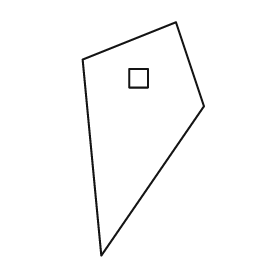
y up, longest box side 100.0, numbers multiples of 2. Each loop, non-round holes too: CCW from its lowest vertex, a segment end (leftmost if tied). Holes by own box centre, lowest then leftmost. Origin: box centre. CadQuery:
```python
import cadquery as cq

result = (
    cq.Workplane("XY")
    .moveTo(-18.0, -50.0)
    .lineTo(26.0, 14.0)
    .lineTo(14.0, 50.0)
    .lineTo(-26.0, 34.0)
    .close()
    .moveTo(-6.0, 22.0)
    .lineTo(2.0, 22.0)
    .lineTo(2.0, 30.0)
    .lineTo(-6.0, 30.0)
    .close()
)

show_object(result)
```